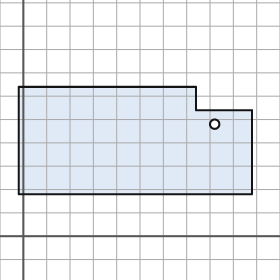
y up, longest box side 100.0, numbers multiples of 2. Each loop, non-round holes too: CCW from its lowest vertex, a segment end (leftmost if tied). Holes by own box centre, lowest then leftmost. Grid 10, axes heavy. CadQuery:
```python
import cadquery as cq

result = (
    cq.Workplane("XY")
    .moveTo(-2.0, 18.0)
    .lineTo(98.0, 18.0)
    .lineTo(98.0, 54.0)
    .lineTo(74.0, 54.0)
    .lineTo(74.0, 64.0)
    .lineTo(-2.0, 64.0)
    .close()
    .moveTo(82.0, 48.0)
    .circle(2.0)
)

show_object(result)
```